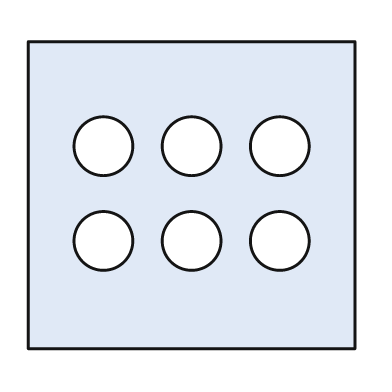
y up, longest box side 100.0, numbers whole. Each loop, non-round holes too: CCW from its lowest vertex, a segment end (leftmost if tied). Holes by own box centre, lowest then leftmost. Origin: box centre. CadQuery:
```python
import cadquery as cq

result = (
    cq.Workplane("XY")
    .moveTo(-50.0, -47.0)
    .lineTo(50.0, -47.0)
    .lineTo(50.0, 47.0)
    .lineTo(-50.0, 47.0)
    .close()
    .moveTo(-27.0, -14.0)
    .circle(9.0)
    .moveTo(0.0, -14.0)
    .circle(9.0)
    .moveTo(27.0, -14.0)
    .circle(9.0)
    .moveTo(-27.0, 15.0)
    .circle(9.0)
    .moveTo(0.0, 15.0)
    .circle(9.0)
    .moveTo(27.0, 15.0)
    .circle(9.0)
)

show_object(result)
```